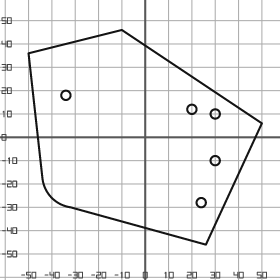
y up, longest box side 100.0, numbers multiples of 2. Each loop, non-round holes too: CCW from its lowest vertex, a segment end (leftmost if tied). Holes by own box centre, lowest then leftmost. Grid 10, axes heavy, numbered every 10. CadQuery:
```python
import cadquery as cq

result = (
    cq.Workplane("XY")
    .moveTo(26.0, -46.0)
    .lineTo(50.0, 6.0)
    .lineTo(-10.0, 46.0)
    .lineTo(-50.0, 36.0)
    .lineTo(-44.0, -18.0)
    .threePointArc((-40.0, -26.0), (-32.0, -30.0))
    .close()
    .moveTo(24.0, -28.0)
    .circle(2.0)
    .moveTo(30.0, -10.0)
    .circle(2.0)
    .moveTo(30.0, 10.0)
    .circle(2.0)
    .moveTo(20.0, 12.0)
    .circle(2.0)
    .moveTo(-34.0, 18.0)
    .circle(2.0)
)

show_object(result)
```